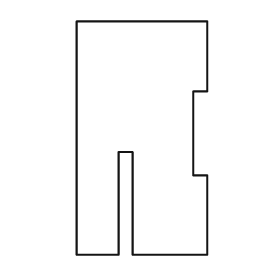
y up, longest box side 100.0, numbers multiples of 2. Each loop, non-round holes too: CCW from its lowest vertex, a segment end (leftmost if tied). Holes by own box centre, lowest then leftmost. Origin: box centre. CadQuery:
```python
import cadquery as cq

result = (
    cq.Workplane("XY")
    .moveTo(-28.0, -50.0)
    .lineTo(-10.0, -50.0)
    .lineTo(-10.0, -6.0)
    .lineTo(-4.0, -6.0)
    .lineTo(-4.0, -50.0)
    .lineTo(28.0, -50.0)
    .lineTo(28.0, -16.0)
    .lineTo(22.0, -16.0)
    .lineTo(22.0, 20.0)
    .lineTo(28.0, 20.0)
    .lineTo(28.0, 50.0)
    .lineTo(-28.0, 50.0)
    .close()
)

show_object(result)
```